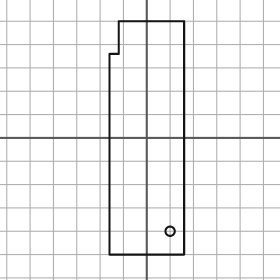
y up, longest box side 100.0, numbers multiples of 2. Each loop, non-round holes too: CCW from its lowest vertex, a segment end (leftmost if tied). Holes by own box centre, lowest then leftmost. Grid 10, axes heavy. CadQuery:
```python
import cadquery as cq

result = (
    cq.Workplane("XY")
    .moveTo(-16.0, -50.0)
    .lineTo(16.0, -50.0)
    .lineTo(16.0, 50.0)
    .lineTo(-12.0, 50.0)
    .lineTo(-12.0, 36.0)
    .lineTo(-16.0, 36.0)
    .close()
    .moveTo(10.0, -40.0)
    .circle(2.0)
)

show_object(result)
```